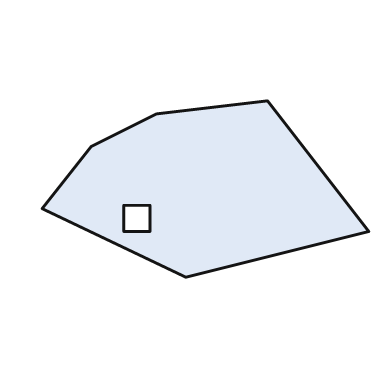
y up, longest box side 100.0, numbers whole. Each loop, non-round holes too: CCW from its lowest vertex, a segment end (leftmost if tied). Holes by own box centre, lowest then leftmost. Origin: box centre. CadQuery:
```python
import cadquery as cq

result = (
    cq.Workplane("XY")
    .moveTo(-6.0, -27.0)
    .lineTo(50.0, -13.0)
    .lineTo(19.0, 27.0)
    .lineTo(-15.0, 23.0)
    .lineTo(-35.0, 13.0)
    .lineTo(-50.0, -6.0)
    .close()
    .moveTo(-25.0, -13.0)
    .lineTo(-17.0, -13.0)
    .lineTo(-17.0, -5.0)
    .lineTo(-25.0, -5.0)
    .close()
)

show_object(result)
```